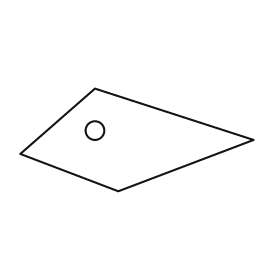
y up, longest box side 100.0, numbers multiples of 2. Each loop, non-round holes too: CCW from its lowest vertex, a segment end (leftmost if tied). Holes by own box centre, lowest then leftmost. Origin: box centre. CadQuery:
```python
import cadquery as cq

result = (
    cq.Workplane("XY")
    .moveTo(-8.0, -22.0)
    .lineTo(50.0, 0.0)
    .lineTo(-18.0, 22.0)
    .lineTo(-50.0, -6.0)
    .close()
    .moveTo(-18.0, 4.0)
    .circle(4.0)
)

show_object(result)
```